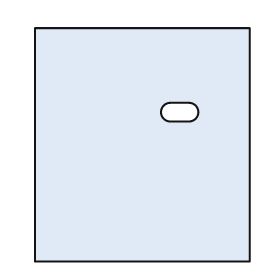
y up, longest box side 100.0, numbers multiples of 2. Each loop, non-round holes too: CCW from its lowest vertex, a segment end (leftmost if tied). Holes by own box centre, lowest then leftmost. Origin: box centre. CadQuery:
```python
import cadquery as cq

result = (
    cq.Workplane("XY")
    .moveTo(-46.0, -50.0)
    .lineTo(46.0, -50.0)
    .lineTo(46.0, 50.0)
    .lineTo(-46.0, 50.0)
    .close()
    .moveTo(12.0, 10.0)
    .lineTo(20.0, 10.0)
    .threePointArc((24.0, 14.0), (20.0, 18.0))
    .lineTo(12.0, 18.0)
    .threePointArc((8.0, 14.0), (12.0, 10.0))
    .close()
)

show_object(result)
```